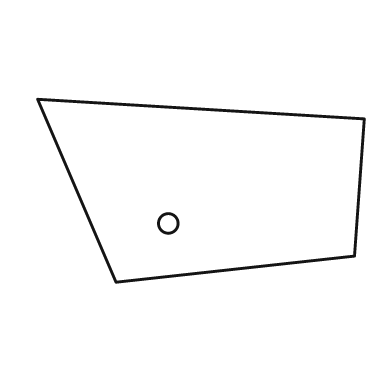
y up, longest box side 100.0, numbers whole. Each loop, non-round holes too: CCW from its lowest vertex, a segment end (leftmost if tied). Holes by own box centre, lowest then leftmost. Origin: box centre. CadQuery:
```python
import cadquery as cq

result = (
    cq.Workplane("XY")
    .moveTo(-26.0, -28.0)
    .lineTo(47.0, -20.0)
    .lineTo(50.0, 22.0)
    .lineTo(-50.0, 28.0)
    .close()
    .moveTo(-10.0, -10.0)
    .circle(3.0)
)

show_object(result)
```